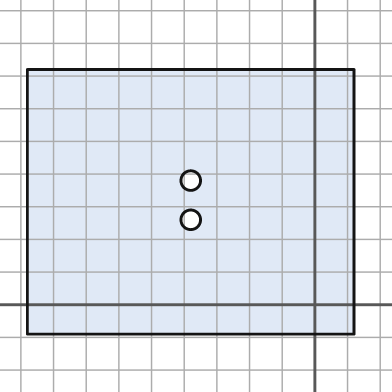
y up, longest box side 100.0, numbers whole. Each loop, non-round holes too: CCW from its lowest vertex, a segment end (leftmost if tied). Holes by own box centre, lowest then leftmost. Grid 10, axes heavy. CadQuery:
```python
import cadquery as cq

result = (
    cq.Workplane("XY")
    .moveTo(-88.0, -9.0)
    .lineTo(12.0, -9.0)
    .lineTo(12.0, 72.0)
    .lineTo(-88.0, 72.0)
    .close()
    .moveTo(-38.0, 26.0)
    .circle(3.0)
    .moveTo(-38.0, 38.0)
    .circle(3.0)
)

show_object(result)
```